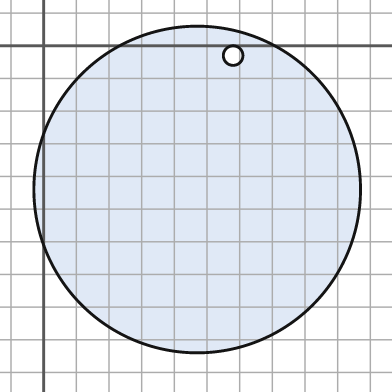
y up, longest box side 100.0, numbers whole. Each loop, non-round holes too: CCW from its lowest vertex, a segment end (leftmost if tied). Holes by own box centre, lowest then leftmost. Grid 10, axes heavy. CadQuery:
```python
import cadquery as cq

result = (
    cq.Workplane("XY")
    .moveTo(47.0, -44.0)
    .circle(50.0)
    .moveTo(58.0, -3.0)
    .circle(3.0)
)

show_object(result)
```